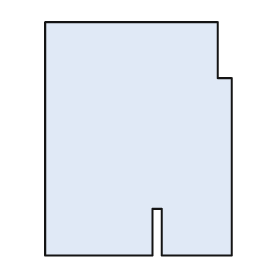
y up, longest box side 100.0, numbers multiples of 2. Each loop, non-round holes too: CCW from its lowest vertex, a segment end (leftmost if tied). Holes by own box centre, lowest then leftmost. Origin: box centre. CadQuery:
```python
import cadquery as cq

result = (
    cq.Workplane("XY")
    .moveTo(-40.0, -50.0)
    .lineTo(6.0, -50.0)
    .lineTo(6.0, -30.0)
    .lineTo(10.0, -30.0)
    .lineTo(10.0, -50.0)
    .lineTo(40.0, -50.0)
    .lineTo(40.0, 26.0)
    .lineTo(34.0, 26.0)
    .lineTo(34.0, 50.0)
    .lineTo(-40.0, 50.0)
    .close()
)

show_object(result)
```